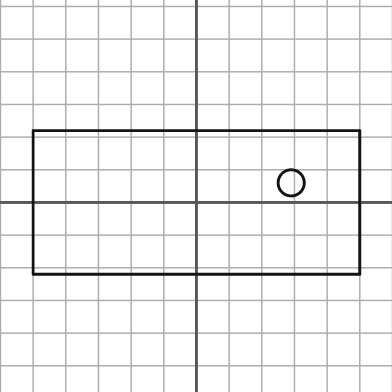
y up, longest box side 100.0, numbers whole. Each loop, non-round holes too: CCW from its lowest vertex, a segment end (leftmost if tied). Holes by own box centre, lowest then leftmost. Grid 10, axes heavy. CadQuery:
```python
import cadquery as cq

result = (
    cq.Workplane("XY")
    .moveTo(-50.0, -22.0)
    .lineTo(50.0, -22.0)
    .lineTo(50.0, 22.0)
    .lineTo(-50.0, 22.0)
    .close()
    .moveTo(29.0, 6.0)
    .circle(4.0)
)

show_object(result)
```